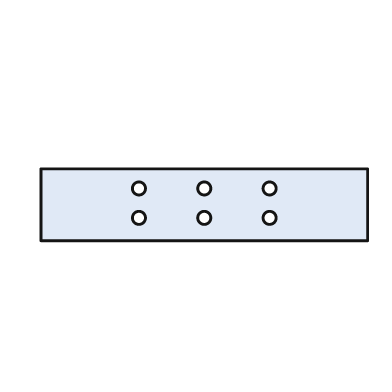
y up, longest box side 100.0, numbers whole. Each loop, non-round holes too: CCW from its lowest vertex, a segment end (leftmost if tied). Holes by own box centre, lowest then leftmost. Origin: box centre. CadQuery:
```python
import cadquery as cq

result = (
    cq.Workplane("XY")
    .moveTo(-50.0, -11.0)
    .lineTo(50.0, -11.0)
    .lineTo(50.0, 11.0)
    .lineTo(-50.0, 11.0)
    .close()
    .moveTo(-20.0, -4.0)
    .circle(2.0)
    .moveTo(0.0, -4.0)
    .circle(2.0)
    .moveTo(20.0, -4.0)
    .circle(2.0)
    .moveTo(-20.0, 5.0)
    .circle(2.0)
    .moveTo(0.0, 5.0)
    .circle(2.0)
    .moveTo(20.0, 5.0)
    .circle(2.0)
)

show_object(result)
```